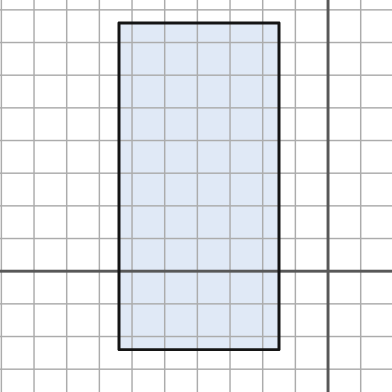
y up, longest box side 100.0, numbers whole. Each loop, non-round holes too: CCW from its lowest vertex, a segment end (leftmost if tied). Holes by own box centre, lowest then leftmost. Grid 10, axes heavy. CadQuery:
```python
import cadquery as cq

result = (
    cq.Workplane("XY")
    .moveTo(-64.0, -24.0)
    .lineTo(-15.0, -24.0)
    .lineTo(-15.0, 76.0)
    .lineTo(-64.0, 76.0)
    .close()
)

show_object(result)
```